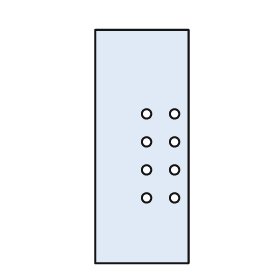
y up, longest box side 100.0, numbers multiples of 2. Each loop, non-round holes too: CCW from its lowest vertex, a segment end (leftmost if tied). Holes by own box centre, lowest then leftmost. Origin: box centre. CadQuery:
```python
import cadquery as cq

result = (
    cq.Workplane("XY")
    .moveTo(-20.0, -50.0)
    .lineTo(20.0, -50.0)
    .lineTo(20.0, 50.0)
    .lineTo(-20.0, 50.0)
    .close()
    .moveTo(2.0, -22.0)
    .circle(2.0)
    .moveTo(14.0, -22.0)
    .circle(2.0)
    .moveTo(2.0, -10.0)
    .circle(2.0)
    .moveTo(14.0, -10.0)
    .circle(2.0)
    .moveTo(2.0, 2.0)
    .circle(2.0)
    .moveTo(14.0, 2.0)
    .circle(2.0)
    .moveTo(2.0, 14.0)
    .circle(2.0)
    .moveTo(14.0, 14.0)
    .circle(2.0)
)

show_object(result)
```